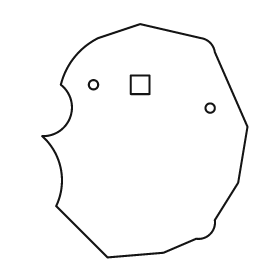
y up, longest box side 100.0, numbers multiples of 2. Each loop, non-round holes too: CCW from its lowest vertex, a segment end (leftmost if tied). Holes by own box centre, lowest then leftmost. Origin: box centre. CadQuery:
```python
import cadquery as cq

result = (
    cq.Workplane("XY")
    .moveTo(-16.0, -50.0)
    .lineTo(8.0, -48.0)
    .lineTo(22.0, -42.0)
    .threePointArc((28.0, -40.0), (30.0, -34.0))
    .lineTo(40.0, -18.0)
    .lineTo(44.0, 6.0)
    .lineTo(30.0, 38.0)
    .threePointArc((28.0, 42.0), (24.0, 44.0))
    .lineTo(-2.0, 50.0)
    .lineTo(-20.0, 44.0)
    .threePointArc((-30.0, 36.0), (-36.0, 24.0))
    .threePointArc((-32.0, 10.0), (-44.0, 2.0))
    .threePointArc((-36.0, -12.0), (-38.0, -28.0))
    .close()
    .moveTo(28.0, 14.0)
    .circle(2.0)
    .moveTo(-22.0, 24.0)
    .circle(2.0)
    .moveTo(-6.0, 20.0)
    .lineTo(2.0, 20.0)
    .lineTo(2.0, 28.0)
    .lineTo(-6.0, 28.0)
    .close()
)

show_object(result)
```